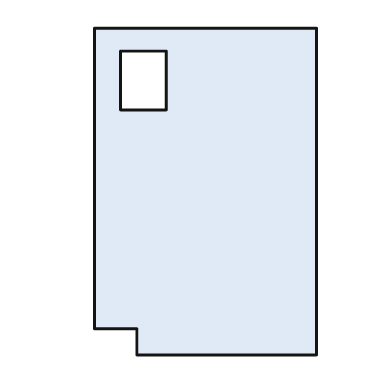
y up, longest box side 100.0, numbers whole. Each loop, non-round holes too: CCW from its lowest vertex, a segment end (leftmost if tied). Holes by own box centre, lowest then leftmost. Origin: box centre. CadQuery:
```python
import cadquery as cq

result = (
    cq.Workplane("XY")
    .moveTo(-21.0, -50.0)
    .lineTo(34.0, -50.0)
    .lineTo(34.0, 50.0)
    .lineTo(-34.0, 50.0)
    .lineTo(-34.0, -42.0)
    .lineTo(-21.0, -42.0)
    .close()
    .moveTo(-26.0, 25.0)
    .lineTo(-12.0, 25.0)
    .lineTo(-12.0, 43.0)
    .lineTo(-26.0, 43.0)
    .close()
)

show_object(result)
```